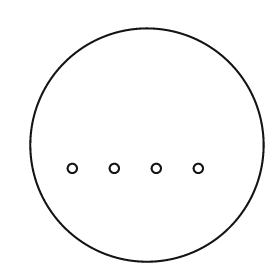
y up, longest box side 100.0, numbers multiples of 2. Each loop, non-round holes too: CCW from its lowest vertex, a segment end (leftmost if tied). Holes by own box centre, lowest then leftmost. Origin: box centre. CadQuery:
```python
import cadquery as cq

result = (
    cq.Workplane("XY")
    .moveTo(0.0, 0.0)
    .circle(50.0)
    .moveTo(-32.0, -10.0)
    .circle(2.0)
    .moveTo(-14.0, -10.0)
    .circle(2.0)
    .moveTo(4.0, -10.0)
    .circle(2.0)
    .moveTo(22.0, -10.0)
    .circle(2.0)
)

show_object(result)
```